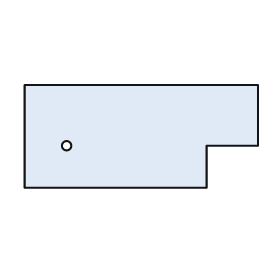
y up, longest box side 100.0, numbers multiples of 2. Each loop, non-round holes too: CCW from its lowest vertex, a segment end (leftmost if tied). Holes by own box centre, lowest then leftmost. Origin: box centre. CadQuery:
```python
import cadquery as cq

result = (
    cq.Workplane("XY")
    .moveTo(-50.0, -22.0)
    .lineTo(28.0, -22.0)
    .lineTo(28.0, -4.0)
    .lineTo(50.0, -4.0)
    .lineTo(50.0, 22.0)
    .lineTo(-50.0, 22.0)
    .close()
    .moveTo(-32.0, -4.0)
    .circle(2.0)
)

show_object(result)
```